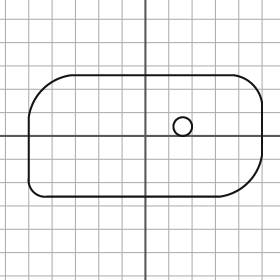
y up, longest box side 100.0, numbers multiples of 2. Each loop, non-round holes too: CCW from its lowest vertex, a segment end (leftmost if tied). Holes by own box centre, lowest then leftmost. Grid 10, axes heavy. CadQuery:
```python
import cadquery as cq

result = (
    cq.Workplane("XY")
    .moveTo(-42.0, -26.0)
    .lineTo(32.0, -26.0)
    .threePointArc((44.0, -20.0), (50.0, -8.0))
    .lineTo(50.0, 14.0)
    .threePointArc((46.0, 22.0), (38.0, 26.0))
    .lineTo(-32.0, 26.0)
    .threePointArc((-44.0, 20.0), (-50.0, 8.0))
    .lineTo(-50.0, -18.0)
    .threePointArc((-48.0, -24.0), (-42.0, -26.0))
    .close()
    .moveTo(16.0, 4.0)
    .circle(4.0)
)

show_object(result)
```